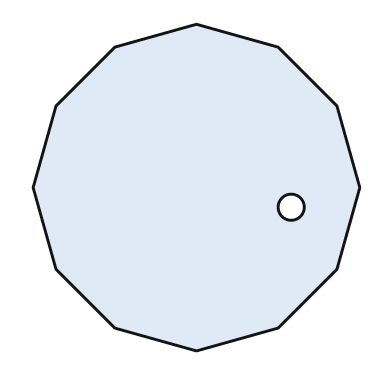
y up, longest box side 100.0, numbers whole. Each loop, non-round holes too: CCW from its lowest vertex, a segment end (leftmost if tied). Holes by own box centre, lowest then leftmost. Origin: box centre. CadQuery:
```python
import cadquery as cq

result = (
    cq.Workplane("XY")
    .moveTo(0.0, -50.0)
    .lineTo(25.0, -43.0)
    .lineTo(43.0, -25.0)
    .lineTo(50.0, 0.0)
    .lineTo(43.0, 25.0)
    .lineTo(25.0, 43.0)
    .lineTo(0.0, 50.0)
    .lineTo(-25.0, 43.0)
    .lineTo(-43.0, 25.0)
    .lineTo(-50.0, 0.0)
    .lineTo(-43.0, -25.0)
    .lineTo(-25.0, -43.0)
    .close()
    .moveTo(29.0, -6.0)
    .circle(4.0)
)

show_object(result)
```